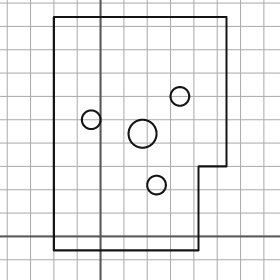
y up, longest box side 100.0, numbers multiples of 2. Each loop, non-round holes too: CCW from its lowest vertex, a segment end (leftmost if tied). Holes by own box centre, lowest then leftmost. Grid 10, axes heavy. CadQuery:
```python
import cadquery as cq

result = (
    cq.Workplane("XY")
    .moveTo(-20.0, -6.0)
    .lineTo(42.0, -6.0)
    .lineTo(42.0, 30.0)
    .lineTo(54.0, 30.0)
    .lineTo(54.0, 94.0)
    .lineTo(-20.0, 94.0)
    .close()
    .moveTo(24.0, 22.0)
    .circle(4.0)
    .moveTo(18.0, 44.0)
    .circle(6.0)
    .moveTo(-4.0, 50.0)
    .circle(4.0)
    .moveTo(34.0, 60.0)
    .circle(4.0)
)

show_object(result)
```